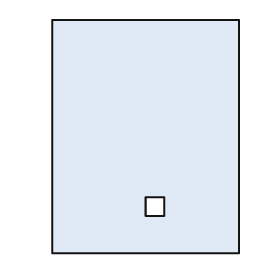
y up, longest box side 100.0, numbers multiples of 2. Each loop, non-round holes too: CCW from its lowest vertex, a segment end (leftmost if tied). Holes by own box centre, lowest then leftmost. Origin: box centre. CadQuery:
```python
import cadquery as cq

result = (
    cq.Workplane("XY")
    .moveTo(-40.0, -50.0)
    .lineTo(40.0, -50.0)
    .lineTo(40.0, 50.0)
    .lineTo(-40.0, 50.0)
    .close()
    .moveTo(0.0, -34.0)
    .lineTo(8.0, -34.0)
    .lineTo(8.0, -26.0)
    .lineTo(0.0, -26.0)
    .close()
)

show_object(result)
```